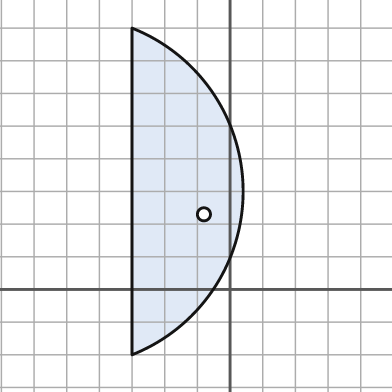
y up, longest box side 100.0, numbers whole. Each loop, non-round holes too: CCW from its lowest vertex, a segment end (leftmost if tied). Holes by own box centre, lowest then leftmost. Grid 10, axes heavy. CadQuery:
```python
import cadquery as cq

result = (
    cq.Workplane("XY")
    .moveTo(-30.0, -20.0)
    .threePointArc((4.0, 30.0), (-30.0, 80.0))
    .close()
    .moveTo(-8.0, 23.0)
    .circle(2.0)
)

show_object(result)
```